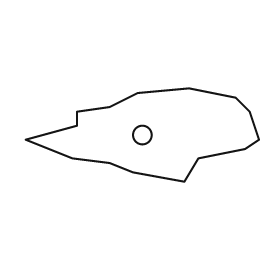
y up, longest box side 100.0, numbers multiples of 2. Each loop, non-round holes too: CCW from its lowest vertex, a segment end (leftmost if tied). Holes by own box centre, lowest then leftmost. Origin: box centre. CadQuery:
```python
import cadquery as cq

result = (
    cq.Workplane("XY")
    .moveTo(18.0, -20.0)
    .lineTo(24.0, -10.0)
    .lineTo(44.0, -6.0)
    .lineTo(50.0, -2.0)
    .lineTo(46.0, 10.0)
    .lineTo(40.0, 16.0)
    .lineTo(20.0, 20.0)
    .lineTo(-2.0, 18.0)
    .lineTo(-14.0, 12.0)
    .lineTo(-28.0, 10.0)
    .lineTo(-28.0, 4.0)
    .lineTo(-50.0, -2.0)
    .lineTo(-30.0, -10.0)
    .lineTo(-14.0, -12.0)
    .lineTo(-4.0, -16.0)
    .close()
    .moveTo(0.0, 0.0)
    .circle(4.0)
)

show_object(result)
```